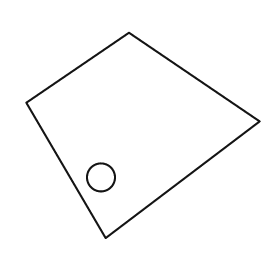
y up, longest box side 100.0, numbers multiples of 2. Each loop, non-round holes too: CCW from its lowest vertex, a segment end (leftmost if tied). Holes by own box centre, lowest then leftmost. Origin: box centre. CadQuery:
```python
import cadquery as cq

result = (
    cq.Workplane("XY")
    .moveTo(-16.0, -44.0)
    .lineTo(50.0, 6.0)
    .lineTo(-6.0, 44.0)
    .lineTo(-50.0, 14.0)
    .close()
    .moveTo(-18.0, -18.0)
    .circle(6.0)
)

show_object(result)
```